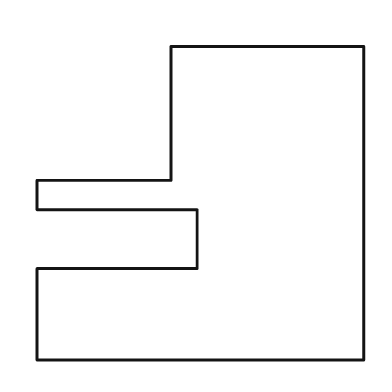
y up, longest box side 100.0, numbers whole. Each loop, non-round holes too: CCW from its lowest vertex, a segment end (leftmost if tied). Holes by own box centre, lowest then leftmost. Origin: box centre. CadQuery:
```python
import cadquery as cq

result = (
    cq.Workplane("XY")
    .moveTo(-50.0, -48.0)
    .lineTo(50.0, -48.0)
    .lineTo(50.0, 48.0)
    .lineTo(-9.0, 48.0)
    .lineTo(-9.0, 7.0)
    .lineTo(-50.0, 7.0)
    .lineTo(-50.0, -2.0)
    .lineTo(-1.0, -2.0)
    .lineTo(-1.0, -20.0)
    .lineTo(-50.0, -20.0)
    .close()
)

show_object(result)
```